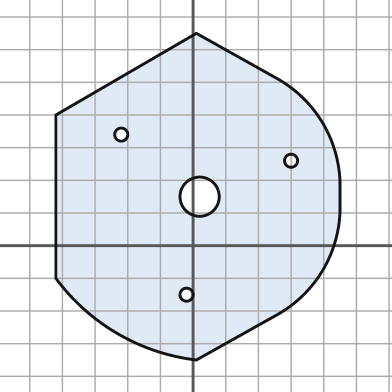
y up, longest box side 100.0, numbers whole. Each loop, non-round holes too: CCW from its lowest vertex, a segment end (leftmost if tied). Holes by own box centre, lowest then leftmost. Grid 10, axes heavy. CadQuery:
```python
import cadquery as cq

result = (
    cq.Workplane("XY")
    .moveTo(1.0, -35.0)
    .lineTo(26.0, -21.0)
    .threePointArc((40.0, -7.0), (45.0, 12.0))
    .lineTo(45.0, 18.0)
    .threePointArc((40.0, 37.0), (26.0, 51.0))
    .lineTo(1.0, 65.0)
    .lineTo(-42.0, 40.0)
    .lineTo(-42.0, -10.0)
    .threePointArc((-23.0, -27.0), (1.0, -35.0))
    .close()
    .moveTo(-2.0, -15.0)
    .circle(2.0)
    .moveTo(2.0, 15.0)
    .circle(6.0)
    .moveTo(30.0, 26.0)
    .circle(2.0)
    .moveTo(-22.0, 34.0)
    .circle(2.0)
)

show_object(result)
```